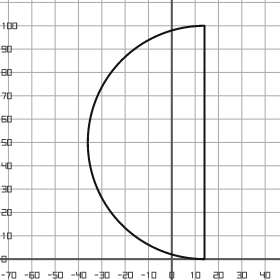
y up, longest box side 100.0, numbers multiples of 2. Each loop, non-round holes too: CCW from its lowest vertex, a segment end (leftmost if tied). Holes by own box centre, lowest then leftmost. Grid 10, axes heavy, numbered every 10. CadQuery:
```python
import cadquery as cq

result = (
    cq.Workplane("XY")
    .moveTo(14.0, 0.0)
    .lineTo(14.0, 100.0)
    .threePointArc((-36.0, 50.0), (14.0, 0.0))
    .close()
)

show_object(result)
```